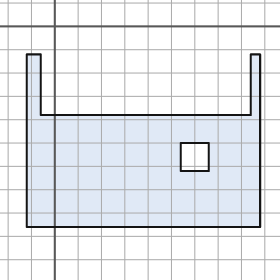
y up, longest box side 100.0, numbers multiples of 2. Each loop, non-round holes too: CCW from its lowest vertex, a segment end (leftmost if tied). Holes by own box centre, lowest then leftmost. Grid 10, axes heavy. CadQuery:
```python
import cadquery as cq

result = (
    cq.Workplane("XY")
    .moveTo(-12.0, -86.0)
    .lineTo(88.0, -86.0)
    .lineTo(88.0, -12.0)
    .lineTo(84.0, -12.0)
    .lineTo(84.0, -38.0)
    .lineTo(-6.0, -38.0)
    .lineTo(-6.0, -12.0)
    .lineTo(-12.0, -12.0)
    .close()
    .moveTo(54.0, -62.0)
    .lineTo(66.0, -62.0)
    .lineTo(66.0, -50.0)
    .lineTo(54.0, -50.0)
    .close()
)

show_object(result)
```